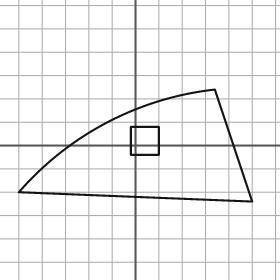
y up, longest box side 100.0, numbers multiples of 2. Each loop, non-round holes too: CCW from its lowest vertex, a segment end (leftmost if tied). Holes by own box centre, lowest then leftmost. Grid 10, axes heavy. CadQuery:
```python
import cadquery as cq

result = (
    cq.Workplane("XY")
    .moveTo(50.0, -24.0)
    .lineTo(34.0, 24.0)
    .threePointArc((-12.0, 10.0), (-50.0, -20.0))
    .close()
    .moveTo(-2.0, -4.0)
    .lineTo(10.0, -4.0)
    .lineTo(10.0, 8.0)
    .lineTo(-2.0, 8.0)
    .close()
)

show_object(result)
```